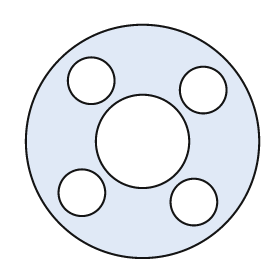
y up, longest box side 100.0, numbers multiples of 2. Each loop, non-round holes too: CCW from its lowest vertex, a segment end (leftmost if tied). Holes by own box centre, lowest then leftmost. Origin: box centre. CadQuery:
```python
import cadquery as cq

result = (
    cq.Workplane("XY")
    .moveTo(0.0, 0.0)
    .circle(50.0)
    .moveTo(22.0, -26.0)
    .circle(10.0)
    .moveTo(-26.0, -22.0)
    .circle(10.0)
    .moveTo(0.0, 0.0)
    .circle(20.0)
    .moveTo(26.0, 22.0)
    .circle(10.0)
    .moveTo(-22.0, 26.0)
    .circle(10.0)
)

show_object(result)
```